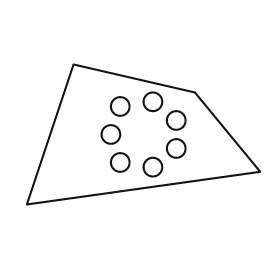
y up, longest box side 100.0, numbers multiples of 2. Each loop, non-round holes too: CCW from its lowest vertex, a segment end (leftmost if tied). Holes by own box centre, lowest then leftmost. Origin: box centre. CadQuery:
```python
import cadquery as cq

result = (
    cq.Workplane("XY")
    .moveTo(-50.0, -30.0)
    .lineTo(50.0, -16.0)
    .lineTo(22.0, 18.0)
    .lineTo(-30.0, 30.0)
    .close()
    .moveTo(4.0, -14.0)
    .circle(4.0)
    .moveTo(-10.0, -12.0)
    .circle(4.0)
    .moveTo(14.0, -6.0)
    .circle(4.0)
    .moveTo(-14.0, 0.0)
    .circle(4.0)
    .moveTo(14.0, 6.0)
    .circle(4.0)
    .moveTo(-10.0, 12.0)
    .circle(4.0)
    .moveTo(4.0, 14.0)
    .circle(4.0)
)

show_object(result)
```